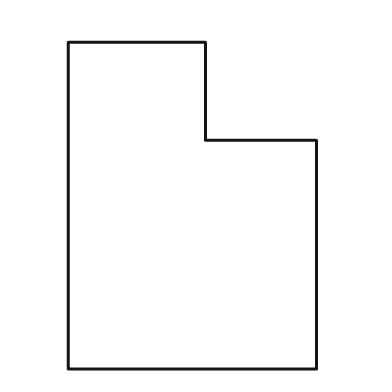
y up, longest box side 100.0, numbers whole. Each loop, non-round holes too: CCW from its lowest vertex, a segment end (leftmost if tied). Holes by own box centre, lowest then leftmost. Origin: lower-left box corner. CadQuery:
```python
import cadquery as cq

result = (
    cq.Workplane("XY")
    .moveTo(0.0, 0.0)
    .lineTo(76.0, 0.0)
    .lineTo(76.0, 70.0)
    .lineTo(42.0, 70.0)
    .lineTo(42.0, 100.0)
    .lineTo(0.0, 100.0)
    .close()
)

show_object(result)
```